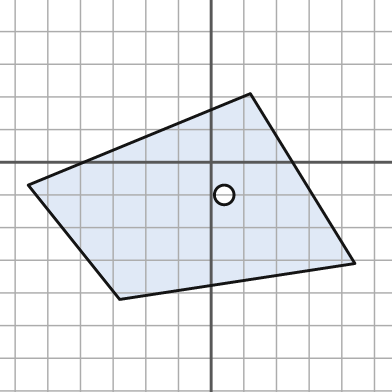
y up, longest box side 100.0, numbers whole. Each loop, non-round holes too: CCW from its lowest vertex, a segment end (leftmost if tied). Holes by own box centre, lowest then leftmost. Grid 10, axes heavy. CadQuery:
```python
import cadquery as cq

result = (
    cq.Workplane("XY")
    .moveTo(-28.0, -42.0)
    .lineTo(44.0, -31.0)
    .lineTo(12.0, 21.0)
    .lineTo(-56.0, -7.0)
    .close()
    .moveTo(4.0, -10.0)
    .circle(3.0)
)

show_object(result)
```